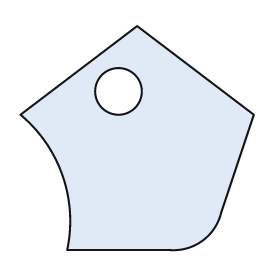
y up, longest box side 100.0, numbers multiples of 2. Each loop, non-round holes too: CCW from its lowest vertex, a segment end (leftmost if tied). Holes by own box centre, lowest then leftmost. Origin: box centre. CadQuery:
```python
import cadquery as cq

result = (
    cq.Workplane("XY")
    .moveTo(-30.0, -48.0)
    .lineTo(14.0, -48.0)
    .threePointArc((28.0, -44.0), (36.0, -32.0))
    .lineTo(50.0, 10.0)
    .lineTo(0.0, 48.0)
    .lineTo(-50.0, 10.0)
    .threePointArc((-32.0, -16.0), (-30.0, -48.0))
    .close()
    .moveTo(-8.0, 20.0)
    .circle(10.0)
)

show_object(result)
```